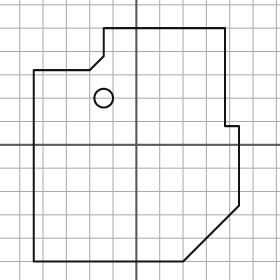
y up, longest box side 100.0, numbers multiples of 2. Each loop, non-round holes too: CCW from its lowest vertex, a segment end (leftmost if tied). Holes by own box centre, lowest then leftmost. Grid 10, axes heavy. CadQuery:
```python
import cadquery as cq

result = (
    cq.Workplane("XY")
    .moveTo(-44.0, -50.0)
    .lineTo(20.0, -50.0)
    .lineTo(44.0, -26.0)
    .lineTo(44.0, 8.0)
    .lineTo(38.0, 8.0)
    .lineTo(38.0, 50.0)
    .lineTo(-14.0, 50.0)
    .lineTo(-14.0, 38.0)
    .lineTo(-20.0, 32.0)
    .lineTo(-44.0, 32.0)
    .close()
    .moveTo(-14.0, 20.0)
    .circle(4.0)
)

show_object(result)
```